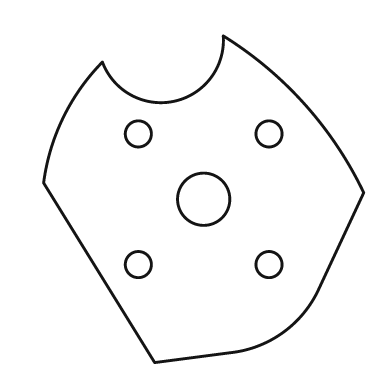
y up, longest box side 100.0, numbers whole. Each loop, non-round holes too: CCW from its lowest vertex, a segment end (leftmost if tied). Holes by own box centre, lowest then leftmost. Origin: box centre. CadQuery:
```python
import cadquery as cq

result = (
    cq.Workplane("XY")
    .moveTo(-15.0, -50.0)
    .lineTo(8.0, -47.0)
    .threePointArc((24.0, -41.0), (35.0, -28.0))
    .lineTo(49.0, 2.0)
    .threePointArc((31.0, 29.0), (6.0, 50.0))
    .threePointArc((-9.0, 30.0), (-31.0, 42.0))
    .threePointArc((-43.0, 25.0), (-49.0, 5.0))
    .close()
    .moveTo(-20.0, -20.0)
    .circle(4.0)
    .moveTo(20.0, -20.0)
    .circle(4.0)
    .moveTo(0.0, 0.0)
    .circle(8.0)
    .moveTo(-20.0, 20.0)
    .circle(4.0)
    .moveTo(20.0, 20.0)
    .circle(4.0)
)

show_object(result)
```